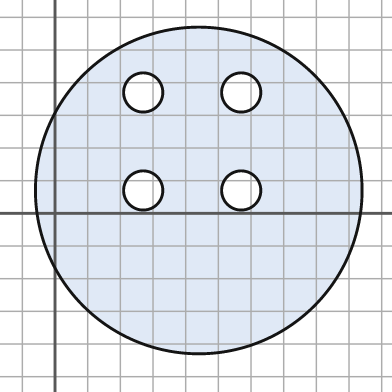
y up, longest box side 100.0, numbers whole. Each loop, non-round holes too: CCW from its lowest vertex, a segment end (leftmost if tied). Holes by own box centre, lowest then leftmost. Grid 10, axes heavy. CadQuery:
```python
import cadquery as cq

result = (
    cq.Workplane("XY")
    .moveTo(44.0, 7.0)
    .circle(50.0)
    .moveTo(27.0, 7.0)
    .circle(6.0)
    .moveTo(57.0, 7.0)
    .circle(6.0)
    .moveTo(27.0, 37.0)
    .circle(6.0)
    .moveTo(57.0, 37.0)
    .circle(6.0)
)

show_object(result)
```